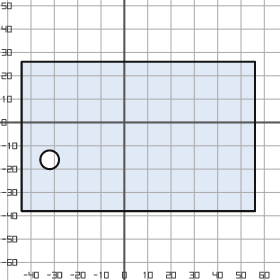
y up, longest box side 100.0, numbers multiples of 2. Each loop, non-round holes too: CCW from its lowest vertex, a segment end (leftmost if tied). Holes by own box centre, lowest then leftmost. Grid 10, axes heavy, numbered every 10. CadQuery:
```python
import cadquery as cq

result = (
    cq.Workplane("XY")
    .moveTo(-44.0, -38.0)
    .lineTo(56.0, -38.0)
    .lineTo(56.0, 26.0)
    .lineTo(-44.0, 26.0)
    .close()
    .moveTo(-32.0, -16.0)
    .circle(4.0)
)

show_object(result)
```